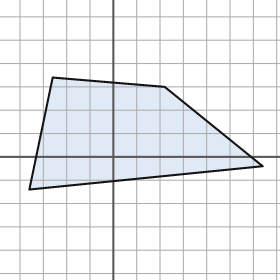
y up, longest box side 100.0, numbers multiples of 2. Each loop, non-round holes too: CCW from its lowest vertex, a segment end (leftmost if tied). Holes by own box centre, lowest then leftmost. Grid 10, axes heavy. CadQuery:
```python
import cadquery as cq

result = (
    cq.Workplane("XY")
    .moveTo(-36.0, -14.0)
    .lineTo(64.0, -4.0)
    .lineTo(22.0, 30.0)
    .lineTo(-26.0, 34.0)
    .close()
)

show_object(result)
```